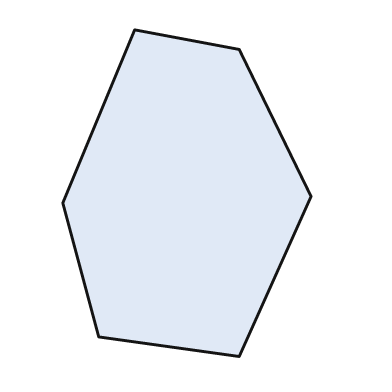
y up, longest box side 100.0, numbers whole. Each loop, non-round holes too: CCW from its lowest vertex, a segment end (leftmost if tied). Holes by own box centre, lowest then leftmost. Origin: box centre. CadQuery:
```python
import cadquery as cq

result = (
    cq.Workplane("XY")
    .moveTo(16.0, -50.0)
    .lineTo(38.0, -1.0)
    .lineTo(16.0, 44.0)
    .lineTo(-16.0, 50.0)
    .lineTo(-38.0, -3.0)
    .lineTo(-27.0, -44.0)
    .close()
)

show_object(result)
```